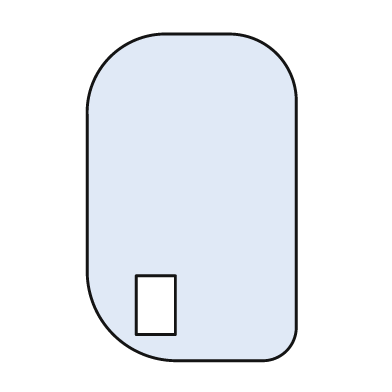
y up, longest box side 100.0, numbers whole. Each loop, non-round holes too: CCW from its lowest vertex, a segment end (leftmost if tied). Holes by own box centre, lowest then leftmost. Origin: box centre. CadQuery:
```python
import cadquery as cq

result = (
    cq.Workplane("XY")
    .moveTo(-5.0, -50.0)
    .lineTo(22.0, -50.0)
    .threePointArc((29.0, -47.0), (32.0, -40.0))
    .lineTo(32.0, 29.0)
    .threePointArc((26.0, 44.0), (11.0, 50.0))
    .lineTo(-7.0, 50.0)
    .threePointArc((-25.0, 43.0), (-32.0, 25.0))
    .lineTo(-32.0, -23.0)
    .threePointArc((-24.0, -42.0), (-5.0, -50.0))
    .close()
    .moveTo(-17.0, -42.0)
    .lineTo(-5.0, -42.0)
    .lineTo(-5.0, -24.0)
    .lineTo(-17.0, -24.0)
    .close()
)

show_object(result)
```